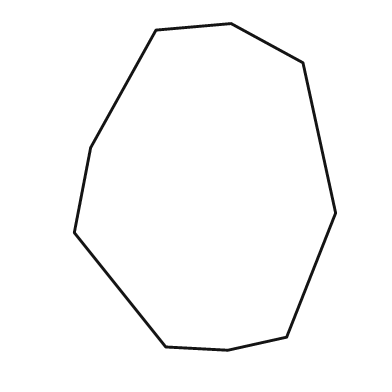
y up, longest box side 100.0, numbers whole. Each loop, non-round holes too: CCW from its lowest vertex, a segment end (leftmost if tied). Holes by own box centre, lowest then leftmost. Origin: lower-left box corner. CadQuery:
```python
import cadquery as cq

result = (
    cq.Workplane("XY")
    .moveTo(47.0, 0.0)
    .lineTo(65.0, 4.0)
    .lineTo(80.0, 42.0)
    .lineTo(70.0, 88.0)
    .lineTo(48.0, 100.0)
    .lineTo(25.0, 98.0)
    .lineTo(5.0, 62.0)
    .lineTo(0.0, 36.0)
    .lineTo(28.0, 1.0)
    .close()
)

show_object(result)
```